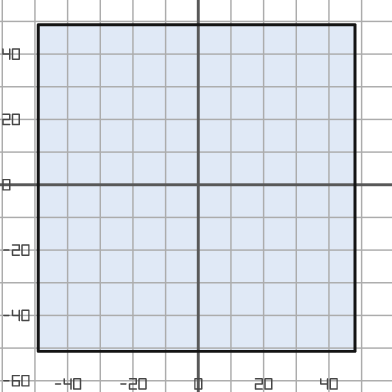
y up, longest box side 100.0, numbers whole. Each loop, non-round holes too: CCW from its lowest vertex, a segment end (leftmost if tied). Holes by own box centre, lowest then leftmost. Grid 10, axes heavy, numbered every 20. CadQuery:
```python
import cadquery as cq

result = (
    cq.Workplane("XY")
    .moveTo(-49.0, -51.0)
    .lineTo(48.0, -51.0)
    .lineTo(48.0, 49.0)
    .lineTo(-49.0, 49.0)
    .close()
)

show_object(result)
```